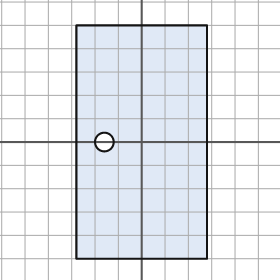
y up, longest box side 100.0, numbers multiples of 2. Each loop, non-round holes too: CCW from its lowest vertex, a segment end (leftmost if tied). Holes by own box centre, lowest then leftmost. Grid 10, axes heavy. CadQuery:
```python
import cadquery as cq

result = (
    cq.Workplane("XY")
    .moveTo(-28.0, -50.0)
    .lineTo(28.0, -50.0)
    .lineTo(28.0, 50.0)
    .lineTo(-28.0, 50.0)
    .close()
    .moveTo(-16.0, 0.0)
    .circle(4.0)
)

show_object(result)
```